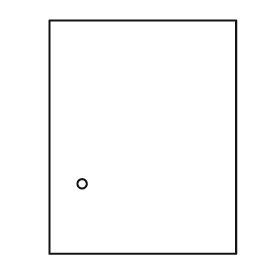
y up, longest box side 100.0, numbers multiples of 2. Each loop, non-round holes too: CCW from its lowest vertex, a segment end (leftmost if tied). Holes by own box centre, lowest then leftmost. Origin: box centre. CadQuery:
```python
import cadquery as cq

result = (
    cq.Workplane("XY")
    .moveTo(-40.0, -50.0)
    .lineTo(40.0, -50.0)
    .lineTo(40.0, 50.0)
    .lineTo(-40.0, 50.0)
    .close()
    .moveTo(-26.0, -20.0)
    .circle(2.0)
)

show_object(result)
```